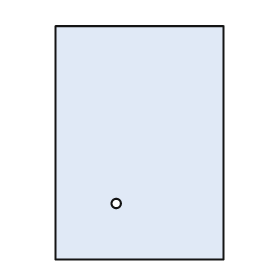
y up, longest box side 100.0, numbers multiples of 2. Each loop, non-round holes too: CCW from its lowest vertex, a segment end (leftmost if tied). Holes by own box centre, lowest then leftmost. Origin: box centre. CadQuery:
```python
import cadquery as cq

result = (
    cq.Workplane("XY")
    .moveTo(-36.0, -50.0)
    .lineTo(36.0, -50.0)
    .lineTo(36.0, 50.0)
    .lineTo(-36.0, 50.0)
    .close()
    .moveTo(-10.0, -26.0)
    .circle(2.0)
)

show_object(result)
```